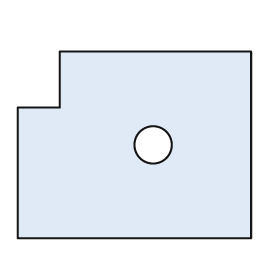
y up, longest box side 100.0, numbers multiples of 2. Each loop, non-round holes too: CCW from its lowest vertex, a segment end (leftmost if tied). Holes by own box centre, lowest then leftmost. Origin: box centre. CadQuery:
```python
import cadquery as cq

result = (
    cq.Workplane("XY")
    .moveTo(-50.0, -40.0)
    .lineTo(50.0, -40.0)
    .lineTo(50.0, 40.0)
    .lineTo(-32.0, 40.0)
    .lineTo(-32.0, 16.0)
    .lineTo(-50.0, 16.0)
    .close()
    .moveTo(8.0, 0.0)
    .circle(8.0)
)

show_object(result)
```